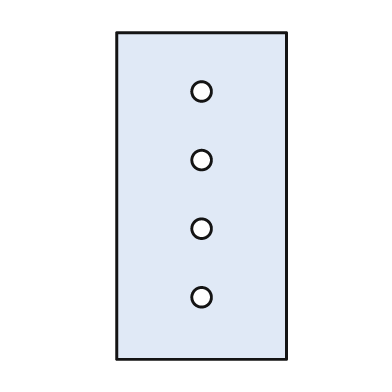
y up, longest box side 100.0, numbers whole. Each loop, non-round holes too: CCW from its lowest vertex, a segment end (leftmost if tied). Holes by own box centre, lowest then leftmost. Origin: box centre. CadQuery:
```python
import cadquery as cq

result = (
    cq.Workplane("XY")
    .moveTo(-26.0, -50.0)
    .lineTo(26.0, -50.0)
    .lineTo(26.0, 50.0)
    .lineTo(-26.0, 50.0)
    .close()
    .moveTo(0.0, -31.0)
    .circle(3.0)
    .moveTo(0.0, -10.0)
    .circle(3.0)
    .moveTo(0.0, 11.0)
    .circle(3.0)
    .moveTo(0.0, 32.0)
    .circle(3.0)
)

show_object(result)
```